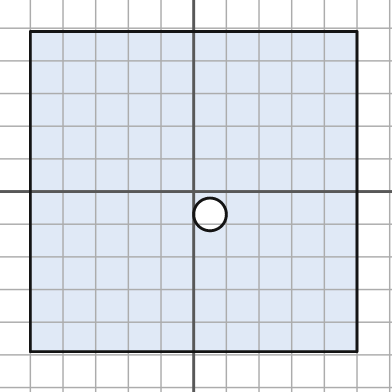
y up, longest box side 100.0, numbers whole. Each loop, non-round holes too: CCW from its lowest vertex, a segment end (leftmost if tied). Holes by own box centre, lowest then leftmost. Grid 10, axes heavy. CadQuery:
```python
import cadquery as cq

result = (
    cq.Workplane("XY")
    .moveTo(-50.0, -49.0)
    .lineTo(50.0, -49.0)
    .lineTo(50.0, 49.0)
    .lineTo(-50.0, 49.0)
    .close()
    .moveTo(5.0, -7.0)
    .circle(5.0)
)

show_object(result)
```